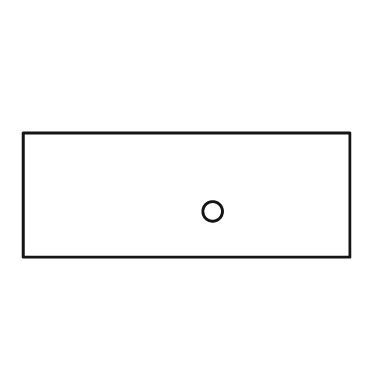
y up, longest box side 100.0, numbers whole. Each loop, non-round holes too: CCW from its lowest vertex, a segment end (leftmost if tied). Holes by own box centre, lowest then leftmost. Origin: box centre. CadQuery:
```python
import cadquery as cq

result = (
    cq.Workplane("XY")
    .moveTo(-50.0, -19.0)
    .lineTo(50.0, -19.0)
    .lineTo(50.0, 19.0)
    .lineTo(-50.0, 19.0)
    .close()
    .moveTo(8.0, -5.0)
    .circle(3.0)
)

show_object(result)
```